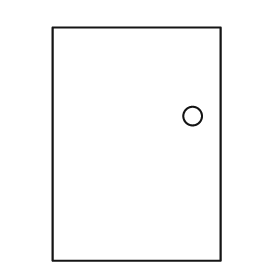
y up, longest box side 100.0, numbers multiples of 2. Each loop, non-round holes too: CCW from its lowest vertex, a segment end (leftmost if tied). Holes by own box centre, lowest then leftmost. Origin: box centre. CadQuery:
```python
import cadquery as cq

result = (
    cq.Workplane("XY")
    .moveTo(-36.0, -50.0)
    .lineTo(36.0, -50.0)
    .lineTo(36.0, 50.0)
    .lineTo(-36.0, 50.0)
    .close()
    .moveTo(24.0, 12.0)
    .circle(4.0)
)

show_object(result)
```